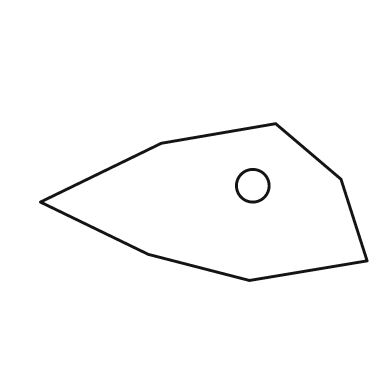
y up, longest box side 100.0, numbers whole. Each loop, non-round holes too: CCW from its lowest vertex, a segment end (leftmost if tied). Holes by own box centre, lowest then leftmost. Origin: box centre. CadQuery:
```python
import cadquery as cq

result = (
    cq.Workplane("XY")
    .moveTo(14.0, -24.0)
    .lineTo(50.0, -18.0)
    .lineTo(42.0, 7.0)
    .lineTo(22.0, 24.0)
    .lineTo(-13.0, 18.0)
    .lineTo(-50.0, 0.0)
    .lineTo(-17.0, -16.0)
    .close()
    .moveTo(15.0, 5.0)
    .circle(5.0)
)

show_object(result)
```